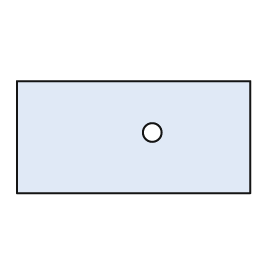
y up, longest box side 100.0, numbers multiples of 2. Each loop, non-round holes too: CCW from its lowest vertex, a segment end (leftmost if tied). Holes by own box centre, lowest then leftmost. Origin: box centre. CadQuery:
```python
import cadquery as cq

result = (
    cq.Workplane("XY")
    .moveTo(-50.0, -24.0)
    .lineTo(50.0, -24.0)
    .lineTo(50.0, 24.0)
    .lineTo(-50.0, 24.0)
    .close()
    .moveTo(8.0, 2.0)
    .circle(4.0)
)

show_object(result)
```